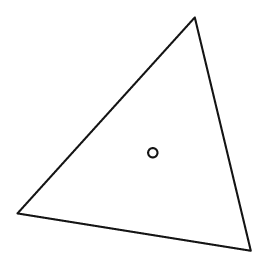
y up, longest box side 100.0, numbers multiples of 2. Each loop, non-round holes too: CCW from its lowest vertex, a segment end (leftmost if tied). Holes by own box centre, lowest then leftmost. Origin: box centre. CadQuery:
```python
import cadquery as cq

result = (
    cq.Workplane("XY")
    .moveTo(50.0, -50.0)
    .lineTo(26.0, 50.0)
    .lineTo(-50.0, -34.0)
    .close()
    .moveTo(8.0, -8.0)
    .circle(2.0)
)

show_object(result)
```